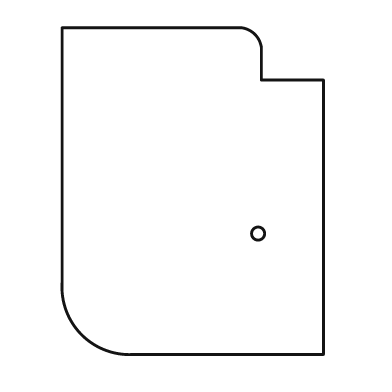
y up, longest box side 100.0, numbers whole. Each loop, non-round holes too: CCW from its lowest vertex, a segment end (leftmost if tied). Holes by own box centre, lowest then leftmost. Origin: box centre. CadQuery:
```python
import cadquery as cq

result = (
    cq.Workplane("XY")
    .moveTo(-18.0, -50.0)
    .lineTo(40.0, -50.0)
    .lineTo(40.0, 34.0)
    .lineTo(21.0, 34.0)
    .lineTo(21.0, 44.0)
    .threePointArc((19.0, 48.0), (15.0, 50.0))
    .lineTo(-40.0, 50.0)
    .lineTo(-40.0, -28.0)
    .threePointArc((-34.0, -44.0), (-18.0, -50.0))
    .close()
    .moveTo(20.0, -13.0)
    .circle(2.0)
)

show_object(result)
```